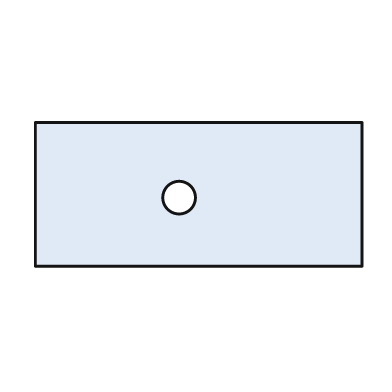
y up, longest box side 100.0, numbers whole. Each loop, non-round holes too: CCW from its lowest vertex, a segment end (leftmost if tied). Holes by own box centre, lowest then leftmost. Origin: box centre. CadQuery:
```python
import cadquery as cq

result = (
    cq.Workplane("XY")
    .moveTo(-50.0, -22.0)
    .lineTo(50.0, -22.0)
    .lineTo(50.0, 22.0)
    .lineTo(-50.0, 22.0)
    .close()
    .moveTo(-6.0, -1.0)
    .circle(5.0)
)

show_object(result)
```